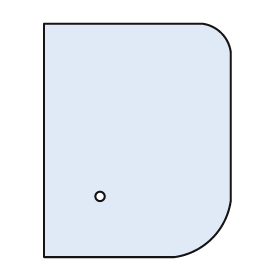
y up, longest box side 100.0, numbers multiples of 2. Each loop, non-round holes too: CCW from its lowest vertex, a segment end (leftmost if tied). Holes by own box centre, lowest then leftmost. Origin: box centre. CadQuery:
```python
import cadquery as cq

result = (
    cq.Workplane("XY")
    .moveTo(-40.0, -50.0)
    .lineTo(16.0, -50.0)
    .threePointArc((32.0, -42.0), (40.0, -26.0))
    .lineTo(40.0, 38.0)
    .threePointArc((36.0, 46.0), (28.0, 50.0))
    .lineTo(-40.0, 50.0)
    .close()
    .moveTo(-16.0, -24.0)
    .circle(2.0)
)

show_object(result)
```